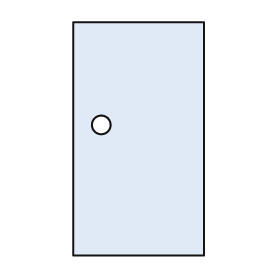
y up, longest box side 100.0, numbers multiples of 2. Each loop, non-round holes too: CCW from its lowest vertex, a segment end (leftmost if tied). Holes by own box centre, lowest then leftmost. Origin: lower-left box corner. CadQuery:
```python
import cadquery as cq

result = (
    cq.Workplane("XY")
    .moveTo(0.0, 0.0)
    .lineTo(56.0, 0.0)
    .lineTo(56.0, 100.0)
    .lineTo(0.0, 100.0)
    .close()
    .moveTo(12.0, 56.0)
    .circle(4.0)
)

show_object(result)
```